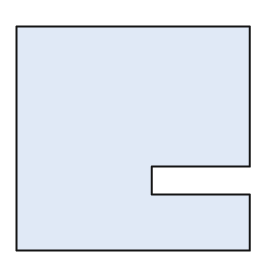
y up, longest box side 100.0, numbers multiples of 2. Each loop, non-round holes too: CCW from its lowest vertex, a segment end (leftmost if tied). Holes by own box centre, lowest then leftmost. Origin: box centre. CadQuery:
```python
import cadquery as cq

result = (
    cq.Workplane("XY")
    .moveTo(-50.0, -48.0)
    .lineTo(50.0, -48.0)
    .lineTo(50.0, -24.0)
    .lineTo(8.0, -24.0)
    .lineTo(8.0, -12.0)
    .lineTo(50.0, -12.0)
    .lineTo(50.0, 48.0)
    .lineTo(-50.0, 48.0)
    .close()
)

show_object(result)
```